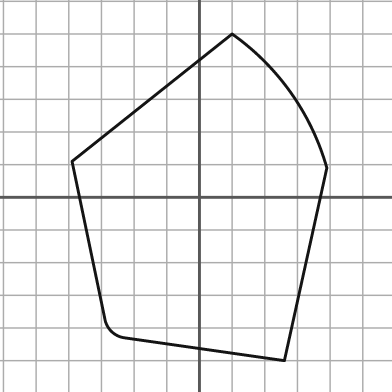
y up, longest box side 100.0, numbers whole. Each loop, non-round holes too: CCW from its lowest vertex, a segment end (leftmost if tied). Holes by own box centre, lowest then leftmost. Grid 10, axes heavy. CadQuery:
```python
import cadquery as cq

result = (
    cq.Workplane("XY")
    .moveTo(26.0, -50.0)
    .lineTo(39.0, 9.0)
    .threePointArc((28.0, 32.0), (10.0, 50.0))
    .lineTo(-39.0, 11.0)
    .lineTo(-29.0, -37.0)
    .threePointArc((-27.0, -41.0), (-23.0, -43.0))
    .close()
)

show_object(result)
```